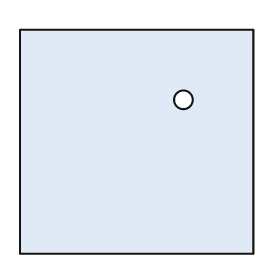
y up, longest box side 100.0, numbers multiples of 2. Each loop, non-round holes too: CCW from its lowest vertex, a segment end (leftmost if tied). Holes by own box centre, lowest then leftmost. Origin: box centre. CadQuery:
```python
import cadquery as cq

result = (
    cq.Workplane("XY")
    .moveTo(-50.0, -48.0)
    .lineTo(50.0, -48.0)
    .lineTo(50.0, 48.0)
    .lineTo(-50.0, 48.0)
    .close()
    .moveTo(20.0, 18.0)
    .circle(4.0)
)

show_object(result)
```